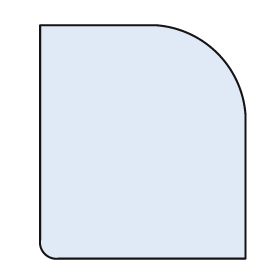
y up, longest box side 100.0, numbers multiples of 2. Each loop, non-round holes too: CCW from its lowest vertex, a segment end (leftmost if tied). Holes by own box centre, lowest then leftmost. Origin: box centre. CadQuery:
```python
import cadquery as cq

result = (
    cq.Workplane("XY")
    .moveTo(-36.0, -50.0)
    .lineTo(44.0, -50.0)
    .lineTo(44.0, 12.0)
    .threePointArc((32.0, 38.0), (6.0, 50.0))
    .lineTo(-44.0, 50.0)
    .lineTo(-44.0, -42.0)
    .threePointArc((-42.0, -48.0), (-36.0, -50.0))
    .close()
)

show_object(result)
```